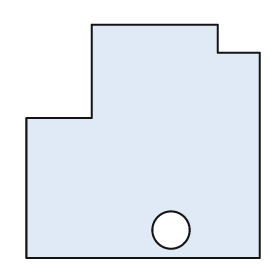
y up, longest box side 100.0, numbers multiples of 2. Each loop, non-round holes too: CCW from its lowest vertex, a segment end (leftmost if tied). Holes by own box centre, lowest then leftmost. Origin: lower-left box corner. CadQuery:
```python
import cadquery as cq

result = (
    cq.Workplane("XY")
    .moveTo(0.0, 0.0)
    .lineTo(100.0, 0.0)
    .lineTo(100.0, 88.0)
    .lineTo(82.0, 88.0)
    .lineTo(82.0, 100.0)
    .lineTo(28.0, 100.0)
    .lineTo(28.0, 60.0)
    .lineTo(0.0, 60.0)
    .close()
    .moveTo(62.0, 12.0)
    .circle(8.0)
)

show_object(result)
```